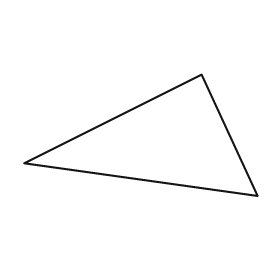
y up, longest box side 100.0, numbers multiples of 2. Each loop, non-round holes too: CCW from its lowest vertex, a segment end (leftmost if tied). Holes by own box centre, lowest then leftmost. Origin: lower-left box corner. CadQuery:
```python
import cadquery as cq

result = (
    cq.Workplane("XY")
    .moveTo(100.0, 0.0)
    .lineTo(76.0, 52.0)
    .lineTo(0.0, 14.0)
    .close()
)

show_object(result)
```